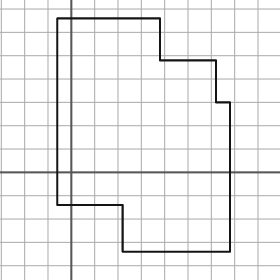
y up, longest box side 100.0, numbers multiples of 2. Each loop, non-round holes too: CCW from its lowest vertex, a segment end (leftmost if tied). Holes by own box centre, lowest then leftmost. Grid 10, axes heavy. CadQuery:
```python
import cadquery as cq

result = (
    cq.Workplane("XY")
    .moveTo(22.0, -34.0)
    .lineTo(68.0, -34.0)
    .lineTo(68.0, 30.0)
    .lineTo(62.0, 30.0)
    .lineTo(62.0, 48.0)
    .lineTo(38.0, 48.0)
    .lineTo(38.0, 66.0)
    .lineTo(-6.0, 66.0)
    .lineTo(-6.0, -14.0)
    .lineTo(22.0, -14.0)
    .close()
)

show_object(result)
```